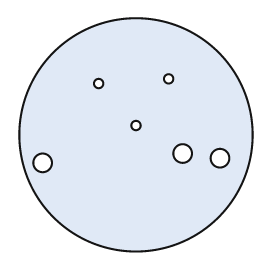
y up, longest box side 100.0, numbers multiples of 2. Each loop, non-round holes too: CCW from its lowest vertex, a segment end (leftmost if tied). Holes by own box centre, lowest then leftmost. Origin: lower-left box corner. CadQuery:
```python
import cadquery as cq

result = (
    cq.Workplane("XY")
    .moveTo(50.0, 50.0)
    .circle(50.0)
    .moveTo(10.0, 38.0)
    .circle(4.0)
    .moveTo(86.0, 40.0)
    .circle(4.0)
    .moveTo(70.0, 42.0)
    .circle(4.0)
    .moveTo(50.0, 54.0)
    .circle(2.0)
    .moveTo(34.0, 72.0)
    .circle(2.0)
    .moveTo(64.0, 74.0)
    .circle(2.0)
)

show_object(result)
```